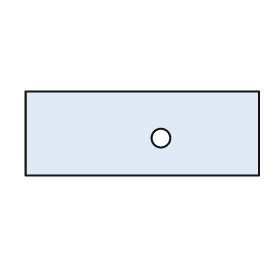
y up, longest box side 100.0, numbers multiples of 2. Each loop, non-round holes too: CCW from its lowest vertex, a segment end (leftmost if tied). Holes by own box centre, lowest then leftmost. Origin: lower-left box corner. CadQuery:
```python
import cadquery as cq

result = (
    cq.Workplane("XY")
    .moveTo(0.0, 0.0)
    .lineTo(100.0, 0.0)
    .lineTo(100.0, 36.0)
    .lineTo(0.0, 36.0)
    .close()
    .moveTo(58.0, 16.0)
    .circle(4.0)
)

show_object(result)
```